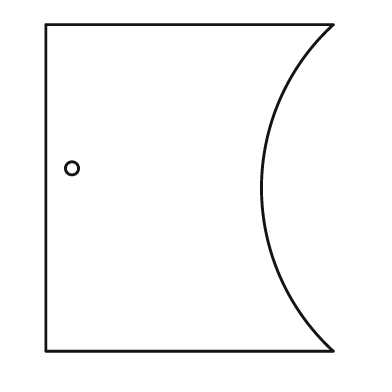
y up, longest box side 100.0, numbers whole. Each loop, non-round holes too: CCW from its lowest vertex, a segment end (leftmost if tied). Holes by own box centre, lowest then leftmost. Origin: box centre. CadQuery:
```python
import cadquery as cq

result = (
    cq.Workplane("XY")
    .moveTo(-44.0, -50.0)
    .lineTo(44.0, -50.0)
    .threePointArc((22.0, 0.0), (44.0, 50.0))
    .lineTo(-44.0, 50.0)
    .close()
    .moveTo(-36.0, 6.0)
    .circle(2.0)
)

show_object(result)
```